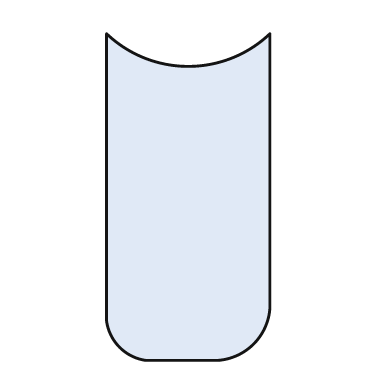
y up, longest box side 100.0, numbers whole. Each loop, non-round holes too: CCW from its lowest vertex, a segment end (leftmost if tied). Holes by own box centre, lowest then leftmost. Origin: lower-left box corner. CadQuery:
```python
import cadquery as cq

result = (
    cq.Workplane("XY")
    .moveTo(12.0, 0.0)
    .lineTo(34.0, 0.0)
    .threePointArc((45.0, 5.0), (50.0, 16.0))
    .lineTo(50.0, 100.0)
    .threePointArc((25.0, 90.0), (0.0, 100.0))
    .lineTo(0.0, 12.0)
    .threePointArc((4.0, 4.0), (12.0, 0.0))
    .close()
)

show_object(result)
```